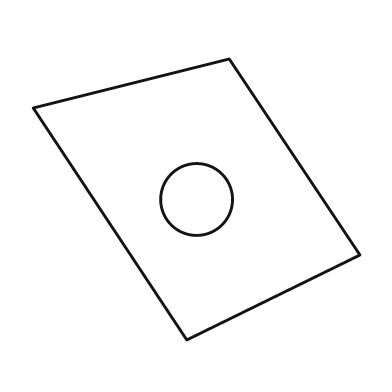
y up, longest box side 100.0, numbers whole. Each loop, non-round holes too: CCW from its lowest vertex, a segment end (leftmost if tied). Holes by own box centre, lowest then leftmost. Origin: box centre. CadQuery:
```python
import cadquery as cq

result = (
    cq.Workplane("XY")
    .moveTo(-3.0, -43.0)
    .lineTo(50.0, -17.0)
    .lineTo(10.0, 43.0)
    .lineTo(-50.0, 28.0)
    .close()
    .moveTo(0.0, 0.0)
    .circle(11.0)
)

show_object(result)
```